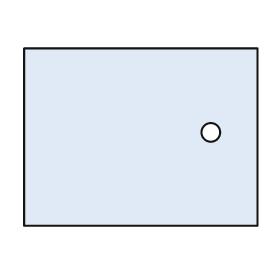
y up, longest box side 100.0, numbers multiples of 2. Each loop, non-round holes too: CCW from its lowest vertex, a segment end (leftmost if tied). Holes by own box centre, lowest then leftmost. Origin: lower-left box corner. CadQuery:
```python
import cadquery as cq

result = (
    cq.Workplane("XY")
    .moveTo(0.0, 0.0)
    .lineTo(100.0, 0.0)
    .lineTo(100.0, 76.0)
    .lineTo(0.0, 76.0)
    .close()
    .moveTo(80.0, 40.0)
    .circle(4.0)
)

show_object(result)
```